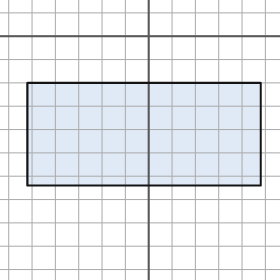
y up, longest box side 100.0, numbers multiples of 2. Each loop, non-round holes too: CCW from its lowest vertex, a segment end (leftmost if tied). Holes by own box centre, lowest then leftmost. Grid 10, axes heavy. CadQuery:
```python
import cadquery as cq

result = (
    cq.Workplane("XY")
    .moveTo(-52.0, -64.0)
    .lineTo(48.0, -64.0)
    .lineTo(48.0, -20.0)
    .lineTo(-52.0, -20.0)
    .close()
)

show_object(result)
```